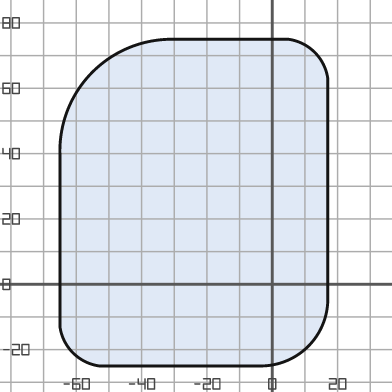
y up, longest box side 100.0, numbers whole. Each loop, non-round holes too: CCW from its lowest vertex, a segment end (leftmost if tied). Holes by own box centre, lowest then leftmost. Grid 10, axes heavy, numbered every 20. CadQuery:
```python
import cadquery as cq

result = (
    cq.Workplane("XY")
    .moveTo(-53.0, -25.0)
    .lineTo(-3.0, -25.0)
    .threePointArc((11.0, -19.0), (17.0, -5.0))
    .lineTo(17.0, 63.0)
    .threePointArc((13.0, 71.0), (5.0, 75.0))
    .lineTo(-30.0, 75.0)
    .threePointArc((-55.0, 65.0), (-65.0, 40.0))
    .lineTo(-65.0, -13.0)
    .threePointArc((-61.0, -21.0), (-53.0, -25.0))
    .close()
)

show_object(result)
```